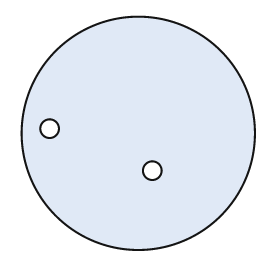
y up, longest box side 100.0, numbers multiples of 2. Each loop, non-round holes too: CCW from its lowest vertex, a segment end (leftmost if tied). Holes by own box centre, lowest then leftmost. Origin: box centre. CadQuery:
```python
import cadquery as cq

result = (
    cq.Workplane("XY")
    .moveTo(0.0, 0.0)
    .circle(50.0)
    .moveTo(6.0, -16.0)
    .circle(4.0)
    .moveTo(-38.0, 2.0)
    .circle(4.0)
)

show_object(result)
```